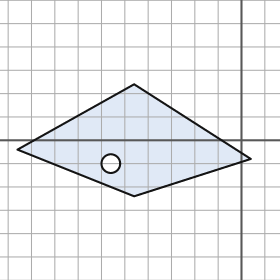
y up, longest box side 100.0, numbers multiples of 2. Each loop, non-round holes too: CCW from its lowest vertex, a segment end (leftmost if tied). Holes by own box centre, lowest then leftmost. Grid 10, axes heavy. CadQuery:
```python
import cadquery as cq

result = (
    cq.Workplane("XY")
    .moveTo(-46.0, -24.0)
    .lineTo(4.0, -8.0)
    .lineTo(-46.0, 24.0)
    .lineTo(-96.0, -4.0)
    .close()
    .moveTo(-56.0, -10.0)
    .circle(4.0)
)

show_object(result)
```